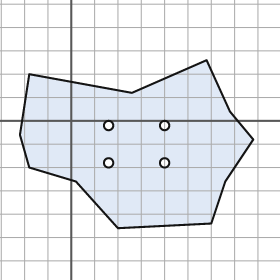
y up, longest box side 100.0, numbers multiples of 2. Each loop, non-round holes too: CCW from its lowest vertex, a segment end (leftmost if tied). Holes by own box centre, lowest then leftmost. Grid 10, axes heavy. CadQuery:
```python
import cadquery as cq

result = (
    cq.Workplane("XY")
    .moveTo(20.0, -46.0)
    .lineTo(60.0, -44.0)
    .lineTo(66.0, -26.0)
    .lineTo(78.0, -8.0)
    .lineTo(68.0, 4.0)
    .lineTo(58.0, 26.0)
    .lineTo(26.0, 12.0)
    .lineTo(-18.0, 20.0)
    .lineTo(-22.0, -6.0)
    .lineTo(-18.0, -20.0)
    .lineTo(2.0, -26.0)
    .close()
    .moveTo(16.0, -18.0)
    .circle(2.0)
    .moveTo(40.0, -18.0)
    .circle(2.0)
    .moveTo(16.0, -2.0)
    .circle(2.0)
    .moveTo(40.0, -2.0)
    .circle(2.0)
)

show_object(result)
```